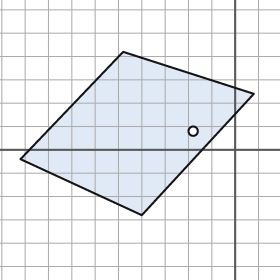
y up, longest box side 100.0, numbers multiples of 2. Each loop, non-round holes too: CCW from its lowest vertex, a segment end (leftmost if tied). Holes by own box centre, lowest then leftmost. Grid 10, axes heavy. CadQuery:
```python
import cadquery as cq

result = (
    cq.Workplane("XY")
    .moveTo(-40.0, -28.0)
    .lineTo(8.0, 24.0)
    .lineTo(-48.0, 42.0)
    .lineTo(-92.0, -4.0)
    .close()
    .moveTo(-18.0, 8.0)
    .circle(2.0)
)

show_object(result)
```